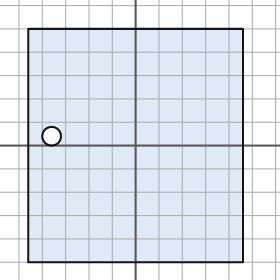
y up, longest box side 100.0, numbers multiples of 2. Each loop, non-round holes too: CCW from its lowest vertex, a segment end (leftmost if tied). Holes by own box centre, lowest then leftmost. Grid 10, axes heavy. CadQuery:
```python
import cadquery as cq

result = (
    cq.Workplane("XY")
    .moveTo(-46.0, -50.0)
    .lineTo(46.0, -50.0)
    .lineTo(46.0, 50.0)
    .lineTo(-46.0, 50.0)
    .close()
    .moveTo(-36.0, 4.0)
    .circle(4.0)
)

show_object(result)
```